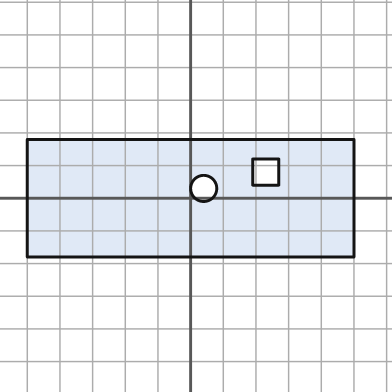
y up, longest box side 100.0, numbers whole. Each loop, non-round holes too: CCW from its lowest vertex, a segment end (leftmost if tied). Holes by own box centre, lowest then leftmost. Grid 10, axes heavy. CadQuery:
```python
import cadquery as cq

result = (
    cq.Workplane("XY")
    .moveTo(-50.0, -18.0)
    .lineTo(50.0, -18.0)
    .lineTo(50.0, 18.0)
    .lineTo(-50.0, 18.0)
    .close()
    .moveTo(4.0, 3.0)
    .circle(4.0)
    .moveTo(19.0, 4.0)
    .lineTo(27.0, 4.0)
    .lineTo(27.0, 12.0)
    .lineTo(19.0, 12.0)
    .close()
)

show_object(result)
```